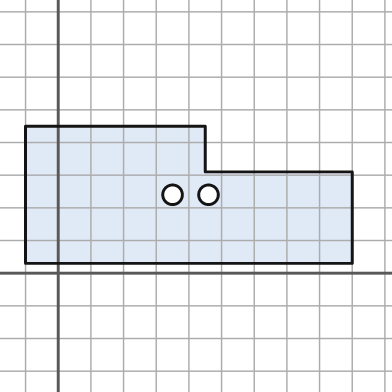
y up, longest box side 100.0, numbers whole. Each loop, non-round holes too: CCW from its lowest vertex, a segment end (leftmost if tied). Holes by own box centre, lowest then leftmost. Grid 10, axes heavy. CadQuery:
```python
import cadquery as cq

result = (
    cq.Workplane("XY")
    .moveTo(-10.0, 3.0)
    .lineTo(90.0, 3.0)
    .lineTo(90.0, 31.0)
    .lineTo(45.0, 31.0)
    .lineTo(45.0, 45.0)
    .lineTo(-10.0, 45.0)
    .close()
    .moveTo(35.0, 24.0)
    .circle(3.0)
    .moveTo(46.0, 24.0)
    .circle(3.0)
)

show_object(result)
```